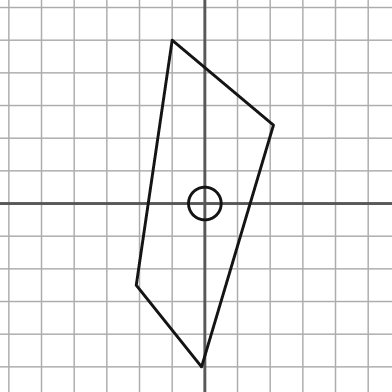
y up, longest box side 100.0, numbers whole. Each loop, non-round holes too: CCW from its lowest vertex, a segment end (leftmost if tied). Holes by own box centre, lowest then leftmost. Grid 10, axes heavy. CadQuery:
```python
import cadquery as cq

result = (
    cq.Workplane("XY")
    .moveTo(-1.0, -50.0)
    .lineTo(21.0, 24.0)
    .lineTo(-10.0, 50.0)
    .lineTo(-21.0, -25.0)
    .close()
    .moveTo(0.0, 0.0)
    .circle(5.0)
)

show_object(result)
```